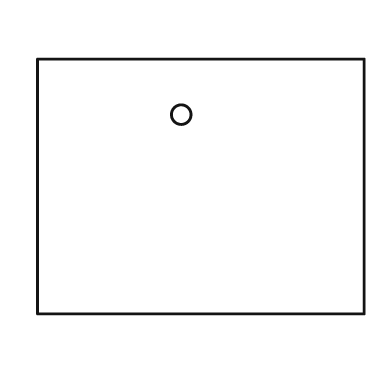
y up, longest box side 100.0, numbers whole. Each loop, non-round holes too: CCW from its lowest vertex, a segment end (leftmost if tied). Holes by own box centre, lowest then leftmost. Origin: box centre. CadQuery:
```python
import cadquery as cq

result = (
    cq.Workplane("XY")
    .moveTo(-50.0, -39.0)
    .lineTo(50.0, -39.0)
    .lineTo(50.0, 39.0)
    .lineTo(-50.0, 39.0)
    .close()
    .moveTo(-6.0, 22.0)
    .circle(3.0)
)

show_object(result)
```